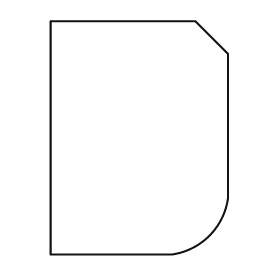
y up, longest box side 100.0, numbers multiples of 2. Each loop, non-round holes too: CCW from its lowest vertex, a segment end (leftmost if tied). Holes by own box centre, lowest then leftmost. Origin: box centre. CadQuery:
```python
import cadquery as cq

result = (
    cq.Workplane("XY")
    .moveTo(-38.0, -50.0)
    .lineTo(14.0, -50.0)
    .threePointArc((30.0, -42.0), (38.0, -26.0))
    .lineTo(38.0, 36.0)
    .lineTo(24.0, 50.0)
    .lineTo(-38.0, 50.0)
    .close()
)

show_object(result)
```